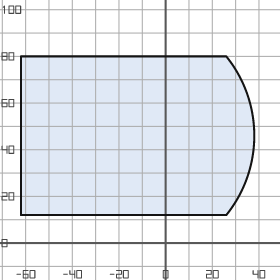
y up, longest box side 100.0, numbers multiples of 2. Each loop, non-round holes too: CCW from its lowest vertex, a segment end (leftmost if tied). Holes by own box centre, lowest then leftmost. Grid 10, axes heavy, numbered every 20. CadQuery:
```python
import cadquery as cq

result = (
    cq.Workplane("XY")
    .moveTo(-62.0, 12.0)
    .lineTo(26.0, 12.0)
    .threePointArc((38.0, 46.0), (26.0, 80.0))
    .lineTo(-62.0, 80.0)
    .close()
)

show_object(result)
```